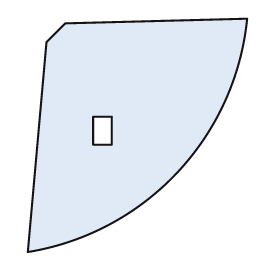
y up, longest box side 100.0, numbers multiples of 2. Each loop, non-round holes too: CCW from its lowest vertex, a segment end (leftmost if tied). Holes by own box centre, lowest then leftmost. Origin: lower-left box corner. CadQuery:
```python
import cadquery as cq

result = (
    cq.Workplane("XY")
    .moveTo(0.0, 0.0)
    .threePointArc((64.0, 34.0), (94.0, 100.0))
    .lineTo(16.0, 98.0)
    .lineTo(8.0, 90.0)
    .close()
    .moveTo(28.0, 46.0)
    .lineTo(36.0, 46.0)
    .lineTo(36.0, 58.0)
    .lineTo(28.0, 58.0)
    .close()
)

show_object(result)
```